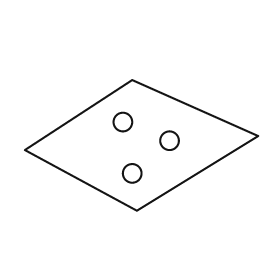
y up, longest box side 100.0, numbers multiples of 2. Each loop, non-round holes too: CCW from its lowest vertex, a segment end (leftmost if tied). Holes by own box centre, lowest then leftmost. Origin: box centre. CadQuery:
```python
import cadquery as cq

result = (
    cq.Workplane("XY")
    .moveTo(-2.0, -28.0)
    .lineTo(50.0, 4.0)
    .lineTo(-4.0, 28.0)
    .lineTo(-50.0, -2.0)
    .close()
    .moveTo(-4.0, -12.0)
    .circle(4.0)
    .moveTo(12.0, 2.0)
    .circle(4.0)
    .moveTo(-8.0, 10.0)
    .circle(4.0)
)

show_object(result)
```